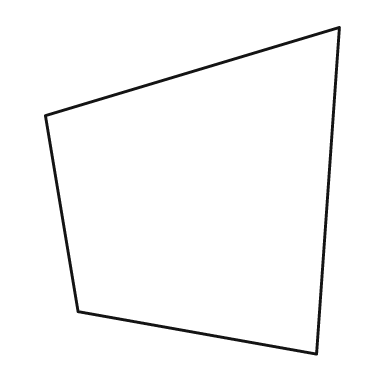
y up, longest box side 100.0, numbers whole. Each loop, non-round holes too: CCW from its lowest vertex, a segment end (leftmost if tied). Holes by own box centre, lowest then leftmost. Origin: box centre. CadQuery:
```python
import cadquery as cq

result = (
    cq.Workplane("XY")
    .moveTo(38.0, -50.0)
    .lineTo(45.0, 50.0)
    .lineTo(-45.0, 23.0)
    .lineTo(-35.0, -37.0)
    .close()
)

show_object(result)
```